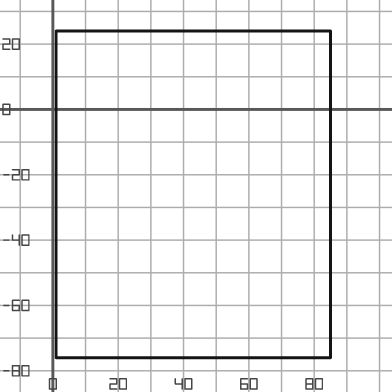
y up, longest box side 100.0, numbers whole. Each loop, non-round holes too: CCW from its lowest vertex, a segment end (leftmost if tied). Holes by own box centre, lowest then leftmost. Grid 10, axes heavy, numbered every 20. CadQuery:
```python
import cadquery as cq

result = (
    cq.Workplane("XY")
    .moveTo(1.0, -76.0)
    .lineTo(85.0, -76.0)
    .lineTo(85.0, 24.0)
    .lineTo(1.0, 24.0)
    .close()
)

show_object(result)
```